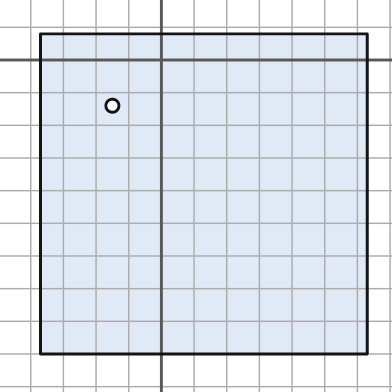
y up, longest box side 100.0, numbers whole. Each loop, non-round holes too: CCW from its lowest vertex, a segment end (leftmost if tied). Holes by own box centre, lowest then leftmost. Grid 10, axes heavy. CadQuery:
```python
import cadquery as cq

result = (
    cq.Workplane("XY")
    .moveTo(-37.0, -90.0)
    .lineTo(63.0, -90.0)
    .lineTo(63.0, 8.0)
    .lineTo(-37.0, 8.0)
    .close()
    .moveTo(-15.0, -14.0)
    .circle(2.0)
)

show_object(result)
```